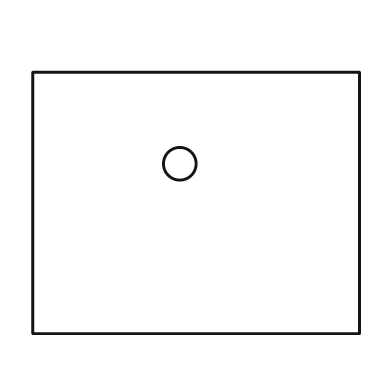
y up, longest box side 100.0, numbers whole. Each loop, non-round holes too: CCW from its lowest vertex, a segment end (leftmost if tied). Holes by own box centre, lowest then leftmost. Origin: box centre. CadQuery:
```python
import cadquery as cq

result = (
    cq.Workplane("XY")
    .moveTo(-50.0, -40.0)
    .lineTo(50.0, -40.0)
    .lineTo(50.0, 40.0)
    .lineTo(-50.0, 40.0)
    .close()
    .moveTo(-5.0, 12.0)
    .circle(5.0)
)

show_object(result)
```